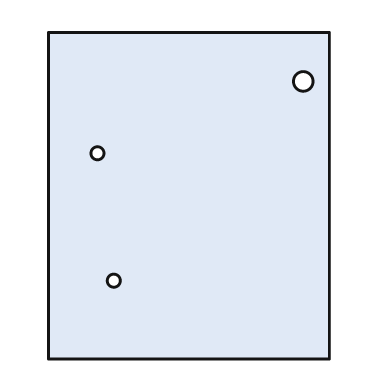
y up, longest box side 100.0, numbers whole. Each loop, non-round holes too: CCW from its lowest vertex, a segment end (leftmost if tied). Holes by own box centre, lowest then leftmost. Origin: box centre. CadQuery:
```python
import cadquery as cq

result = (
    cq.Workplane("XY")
    .moveTo(-43.0, -50.0)
    .lineTo(43.0, -50.0)
    .lineTo(43.0, 50.0)
    .lineTo(-43.0, 50.0)
    .close()
    .moveTo(-23.0, -26.0)
    .circle(2.0)
    .moveTo(-28.0, 13.0)
    .circle(2.0)
    .moveTo(35.0, 35.0)
    .circle(3.0)
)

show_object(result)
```